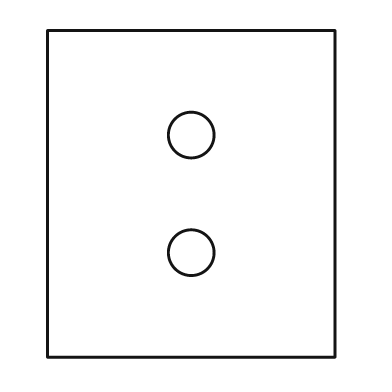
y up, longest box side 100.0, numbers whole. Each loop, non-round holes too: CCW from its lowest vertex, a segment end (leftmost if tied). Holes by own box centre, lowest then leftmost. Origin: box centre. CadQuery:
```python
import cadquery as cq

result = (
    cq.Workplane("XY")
    .moveTo(-44.0, -50.0)
    .lineTo(44.0, -50.0)
    .lineTo(44.0, 50.0)
    .lineTo(-44.0, 50.0)
    .close()
    .moveTo(0.0, -18.0)
    .circle(7.0)
    .moveTo(0.0, 18.0)
    .circle(7.0)
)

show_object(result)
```